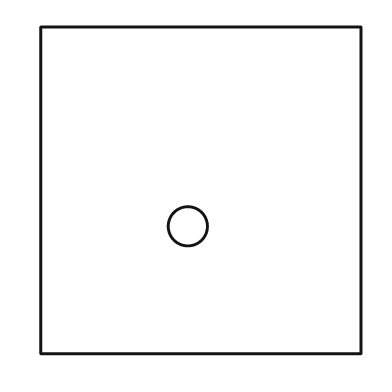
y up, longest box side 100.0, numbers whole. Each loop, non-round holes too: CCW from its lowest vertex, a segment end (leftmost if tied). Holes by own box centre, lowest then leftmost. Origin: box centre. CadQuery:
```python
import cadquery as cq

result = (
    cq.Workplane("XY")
    .moveTo(-49.0, -50.0)
    .lineTo(49.0, -50.0)
    .lineTo(49.0, 50.0)
    .lineTo(-49.0, 50.0)
    .close()
    .moveTo(-4.0, -11.0)
    .circle(6.0)
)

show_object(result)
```